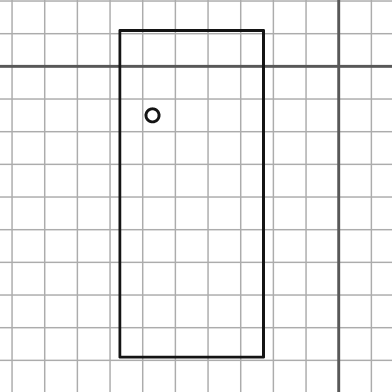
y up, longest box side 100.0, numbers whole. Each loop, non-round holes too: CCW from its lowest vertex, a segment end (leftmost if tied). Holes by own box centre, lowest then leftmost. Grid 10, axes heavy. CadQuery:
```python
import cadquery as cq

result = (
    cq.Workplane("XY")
    .moveTo(-67.0, -89.0)
    .lineTo(-23.0, -89.0)
    .lineTo(-23.0, 11.0)
    .lineTo(-67.0, 11.0)
    .close()
    .moveTo(-57.0, -15.0)
    .circle(2.0)
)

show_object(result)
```